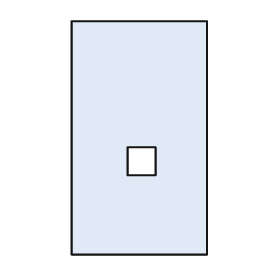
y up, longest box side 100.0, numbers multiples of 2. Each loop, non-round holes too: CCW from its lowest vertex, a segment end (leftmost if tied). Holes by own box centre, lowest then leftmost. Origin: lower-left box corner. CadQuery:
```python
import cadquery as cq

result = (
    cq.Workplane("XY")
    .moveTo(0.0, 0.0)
    .lineTo(58.0, 0.0)
    .lineTo(58.0, 100.0)
    .lineTo(0.0, 100.0)
    .close()
    .moveTo(24.0, 34.0)
    .lineTo(36.0, 34.0)
    .lineTo(36.0, 46.0)
    .lineTo(24.0, 46.0)
    .close()
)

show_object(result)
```